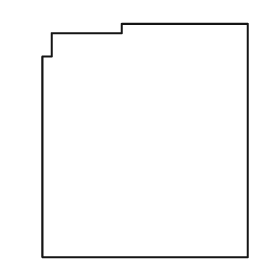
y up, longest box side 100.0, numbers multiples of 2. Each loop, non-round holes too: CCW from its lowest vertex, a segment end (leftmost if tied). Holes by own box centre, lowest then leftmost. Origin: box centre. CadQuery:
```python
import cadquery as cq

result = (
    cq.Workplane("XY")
    .moveTo(-44.0, -50.0)
    .lineTo(44.0, -50.0)
    .lineTo(44.0, 50.0)
    .lineTo(-10.0, 50.0)
    .lineTo(-10.0, 46.0)
    .lineTo(-40.0, 46.0)
    .lineTo(-40.0, 36.0)
    .lineTo(-44.0, 36.0)
    .close()
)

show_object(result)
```